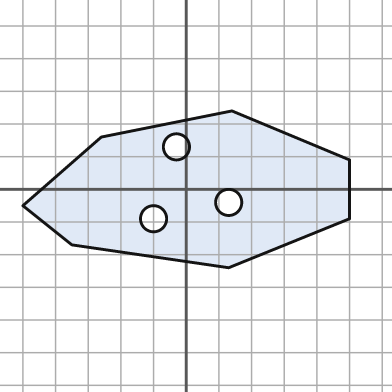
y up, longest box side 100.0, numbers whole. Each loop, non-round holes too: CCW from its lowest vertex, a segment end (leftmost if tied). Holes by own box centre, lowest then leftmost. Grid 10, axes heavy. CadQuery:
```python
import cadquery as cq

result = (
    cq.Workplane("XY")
    .moveTo(13.0, -24.0)
    .lineTo(50.0, -9.0)
    .lineTo(50.0, 9.0)
    .lineTo(14.0, 24.0)
    .lineTo(-26.0, 16.0)
    .lineTo(-50.0, -5.0)
    .lineTo(-35.0, -17.0)
    .close()
    .moveTo(-10.0, -9.0)
    .circle(4.0)
    .moveTo(13.0, -4.0)
    .circle(4.0)
    .moveTo(-3.0, 13.0)
    .circle(4.0)
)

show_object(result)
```